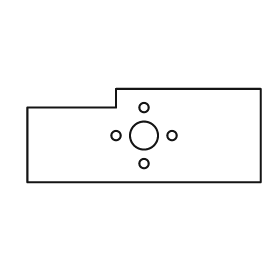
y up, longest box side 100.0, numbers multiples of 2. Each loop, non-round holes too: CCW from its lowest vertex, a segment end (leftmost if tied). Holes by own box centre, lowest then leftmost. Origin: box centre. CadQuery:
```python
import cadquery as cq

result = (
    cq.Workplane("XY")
    .moveTo(-50.0, -20.0)
    .lineTo(50.0, -20.0)
    .lineTo(50.0, 20.0)
    .lineTo(-12.0, 20.0)
    .lineTo(-12.0, 12.0)
    .lineTo(-50.0, 12.0)
    .close()
    .moveTo(0.0, -12.0)
    .circle(2.0)
    .moveTo(-12.0, 0.0)
    .circle(2.0)
    .moveTo(0.0, 0.0)
    .circle(6.0)
    .moveTo(12.0, 0.0)
    .circle(2.0)
    .moveTo(0.0, 12.0)
    .circle(2.0)
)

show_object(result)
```